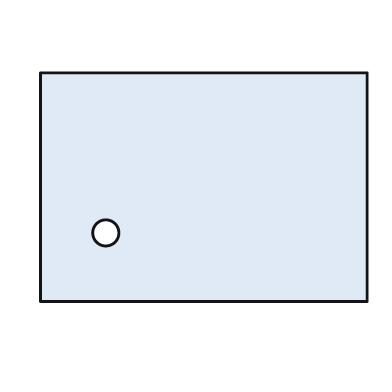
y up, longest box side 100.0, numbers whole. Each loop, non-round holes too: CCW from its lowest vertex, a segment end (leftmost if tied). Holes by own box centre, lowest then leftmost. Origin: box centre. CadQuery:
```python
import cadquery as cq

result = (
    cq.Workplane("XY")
    .moveTo(-50.0, -35.0)
    .lineTo(50.0, -35.0)
    .lineTo(50.0, 35.0)
    .lineTo(-50.0, 35.0)
    .close()
    .moveTo(-30.0, -14.0)
    .circle(4.0)
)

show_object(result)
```